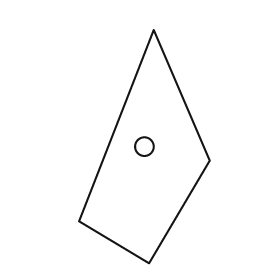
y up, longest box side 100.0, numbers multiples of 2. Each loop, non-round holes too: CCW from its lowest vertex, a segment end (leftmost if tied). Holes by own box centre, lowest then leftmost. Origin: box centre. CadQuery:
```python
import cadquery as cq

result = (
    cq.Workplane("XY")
    .moveTo(2.0, -50.0)
    .lineTo(28.0, -6.0)
    .lineTo(4.0, 50.0)
    .lineTo(-28.0, -32.0)
    .close()
    .moveTo(0.0, 0.0)
    .circle(4.0)
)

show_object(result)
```